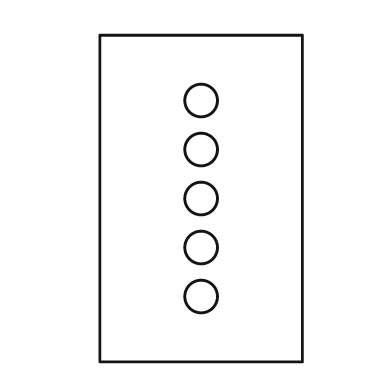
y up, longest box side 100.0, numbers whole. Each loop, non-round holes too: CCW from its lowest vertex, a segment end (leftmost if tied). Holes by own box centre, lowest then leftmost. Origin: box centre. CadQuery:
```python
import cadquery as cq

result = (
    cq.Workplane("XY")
    .moveTo(-31.0, -50.0)
    .lineTo(31.0, -50.0)
    .lineTo(31.0, 50.0)
    .lineTo(-31.0, 50.0)
    .close()
    .moveTo(0.0, -30.0)
    .circle(5.0)
    .moveTo(0.0, -15.0)
    .circle(5.0)
    .moveTo(0.0, 0.0)
    .circle(5.0)
    .moveTo(0.0, 15.0)
    .circle(5.0)
    .moveTo(0.0, 30.0)
    .circle(5.0)
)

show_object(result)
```